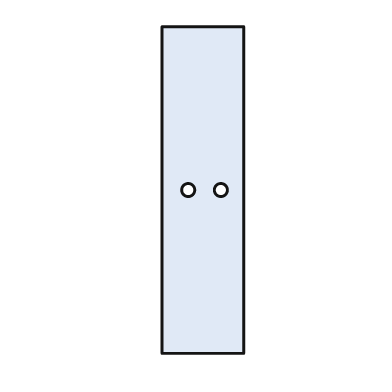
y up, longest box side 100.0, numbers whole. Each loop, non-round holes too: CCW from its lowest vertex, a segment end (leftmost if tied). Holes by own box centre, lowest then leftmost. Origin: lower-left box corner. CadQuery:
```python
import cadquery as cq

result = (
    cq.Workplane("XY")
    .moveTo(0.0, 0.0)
    .lineTo(25.0, 0.0)
    .lineTo(25.0, 100.0)
    .lineTo(0.0, 100.0)
    .close()
    .moveTo(8.0, 50.0)
    .circle(2.0)
    .moveTo(18.0, 50.0)
    .circle(2.0)
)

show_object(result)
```